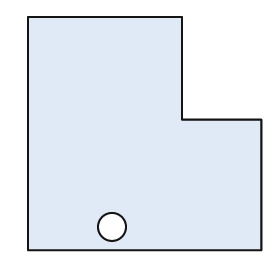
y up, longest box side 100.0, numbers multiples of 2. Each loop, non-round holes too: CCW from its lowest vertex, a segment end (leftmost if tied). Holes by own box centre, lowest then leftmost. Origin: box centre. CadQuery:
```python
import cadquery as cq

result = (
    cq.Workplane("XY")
    .moveTo(-50.0, -50.0)
    .lineTo(50.0, -50.0)
    .lineTo(50.0, 6.0)
    .lineTo(16.0, 6.0)
    .lineTo(16.0, 50.0)
    .lineTo(-50.0, 50.0)
    .close()
    .moveTo(-14.0, -40.0)
    .circle(6.0)
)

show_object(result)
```